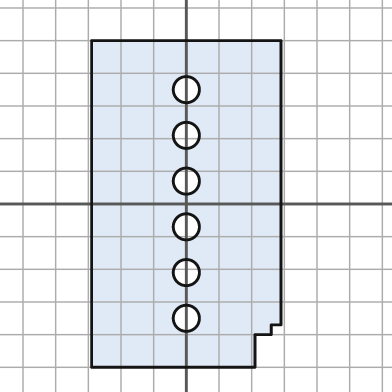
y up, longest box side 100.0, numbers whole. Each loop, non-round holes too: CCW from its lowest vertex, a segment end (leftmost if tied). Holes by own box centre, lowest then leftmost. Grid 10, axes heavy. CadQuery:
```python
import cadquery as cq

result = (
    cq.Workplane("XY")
    .moveTo(-29.0, -50.0)
    .lineTo(21.0, -50.0)
    .lineTo(21.0, -40.0)
    .lineTo(26.0, -40.0)
    .lineTo(26.0, -37.0)
    .lineTo(29.0, -37.0)
    .lineTo(29.0, 50.0)
    .lineTo(-29.0, 50.0)
    .close()
    .moveTo(0.0, -35.0)
    .circle(4.0)
    .moveTo(0.0, -21.0)
    .circle(4.0)
    .moveTo(0.0, -7.0)
    .circle(4.0)
    .moveTo(0.0, 7.0)
    .circle(4.0)
    .moveTo(0.0, 21.0)
    .circle(4.0)
    .moveTo(0.0, 35.0)
    .circle(4.0)
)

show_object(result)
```